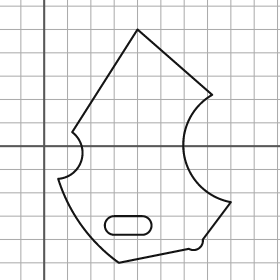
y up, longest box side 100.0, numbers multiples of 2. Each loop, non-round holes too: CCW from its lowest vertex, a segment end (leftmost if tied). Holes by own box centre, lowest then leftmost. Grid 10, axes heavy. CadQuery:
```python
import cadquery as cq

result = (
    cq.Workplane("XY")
    .moveTo(32.0, -50.0)
    .lineTo(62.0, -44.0)
    .threePointArc((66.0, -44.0), (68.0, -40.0))
    .lineTo(80.0, -24.0)
    .threePointArc((60.0, -4.0), (72.0, 22.0))
    .lineTo(40.0, 50.0)
    .lineTo(12.0, 6.0)
    .threePointArc((16.0, -6.0), (6.0, -14.0))
    .threePointArc((16.0, -34.0), (32.0, -50.0))
    .close()
    .moveTo(30.0, -38.0)
    .lineTo(42.0, -38.0)
    .threePointArc((46.0, -34.0), (42.0, -30.0))
    .lineTo(30.0, -30.0)
    .threePointArc((26.0, -34.0), (30.0, -38.0))
    .close()
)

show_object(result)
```